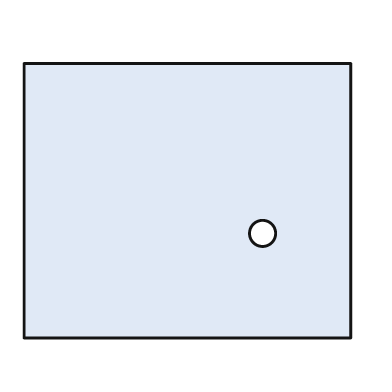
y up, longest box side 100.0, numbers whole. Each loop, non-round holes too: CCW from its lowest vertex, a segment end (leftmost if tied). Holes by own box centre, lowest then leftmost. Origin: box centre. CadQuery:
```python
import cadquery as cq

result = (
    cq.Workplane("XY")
    .moveTo(-50.0, -42.0)
    .lineTo(50.0, -42.0)
    .lineTo(50.0, 42.0)
    .lineTo(-50.0, 42.0)
    .close()
    .moveTo(23.0, -10.0)
    .circle(4.0)
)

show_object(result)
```